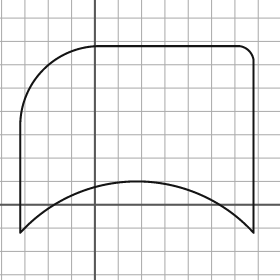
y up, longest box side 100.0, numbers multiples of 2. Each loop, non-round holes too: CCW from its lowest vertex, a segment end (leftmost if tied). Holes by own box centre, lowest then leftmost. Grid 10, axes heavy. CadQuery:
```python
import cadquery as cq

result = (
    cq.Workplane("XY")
    .moveTo(-32.0, -12.0)
    .threePointArc((18.0, 10.0), (68.0, -12.0))
    .lineTo(68.0, 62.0)
    .threePointArc((66.0, 66.0), (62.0, 68.0))
    .lineTo(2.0, 68.0)
    .threePointArc((-22.0, 58.0), (-32.0, 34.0))
    .close()
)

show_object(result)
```